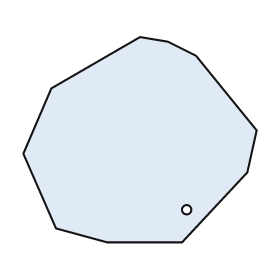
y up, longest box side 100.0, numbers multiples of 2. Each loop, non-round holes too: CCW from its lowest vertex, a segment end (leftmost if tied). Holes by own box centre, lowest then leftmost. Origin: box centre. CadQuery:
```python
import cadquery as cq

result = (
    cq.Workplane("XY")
    .moveTo(-14.0, -44.0)
    .lineTo(18.0, -44.0)
    .lineTo(46.0, -14.0)
    .lineTo(50.0, 4.0)
    .lineTo(24.0, 36.0)
    .lineTo(12.0, 42.0)
    .lineTo(0.0, 44.0)
    .lineTo(-38.0, 22.0)
    .lineTo(-50.0, -6.0)
    .lineTo(-36.0, -38.0)
    .close()
    .moveTo(20.0, -30.0)
    .circle(2.0)
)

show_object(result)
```